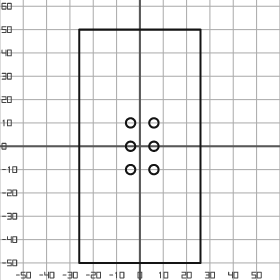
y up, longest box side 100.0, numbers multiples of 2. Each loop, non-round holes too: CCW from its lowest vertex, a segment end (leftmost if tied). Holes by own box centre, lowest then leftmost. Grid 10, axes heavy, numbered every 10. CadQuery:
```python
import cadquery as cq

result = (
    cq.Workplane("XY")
    .moveTo(-26.0, -50.0)
    .lineTo(26.0, -50.0)
    .lineTo(26.0, 50.0)
    .lineTo(-26.0, 50.0)
    .close()
    .moveTo(-4.0, -10.0)
    .circle(2.0)
    .moveTo(6.0, -10.0)
    .circle(2.0)
    .moveTo(-4.0, 0.0)
    .circle(2.0)
    .moveTo(6.0, 0.0)
    .circle(2.0)
    .moveTo(-4.0, 10.0)
    .circle(2.0)
    .moveTo(6.0, 10.0)
    .circle(2.0)
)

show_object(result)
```